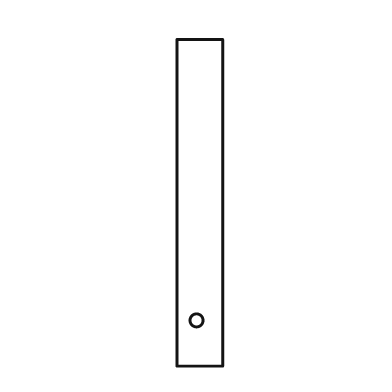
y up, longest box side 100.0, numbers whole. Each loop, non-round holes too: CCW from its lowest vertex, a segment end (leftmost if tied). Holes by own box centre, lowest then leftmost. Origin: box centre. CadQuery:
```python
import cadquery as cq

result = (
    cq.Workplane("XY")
    .moveTo(-7.0, -50.0)
    .lineTo(7.0, -50.0)
    .lineTo(7.0, 50.0)
    .lineTo(-7.0, 50.0)
    .close()
    .moveTo(-1.0, -36.0)
    .circle(2.0)
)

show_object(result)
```